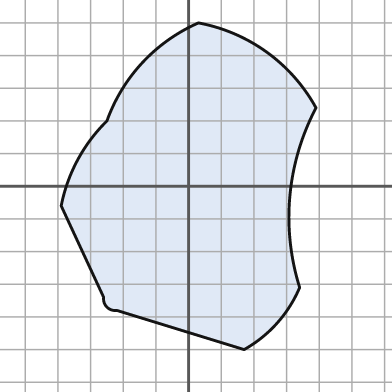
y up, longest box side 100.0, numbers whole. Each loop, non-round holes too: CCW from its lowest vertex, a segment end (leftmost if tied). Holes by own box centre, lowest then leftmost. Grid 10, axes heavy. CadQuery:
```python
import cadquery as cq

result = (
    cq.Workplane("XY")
    .moveTo(17.0, -50.0)
    .threePointArc((27.0, -42.0), (34.0, -31.0))
    .threePointArc((31.0, -3.0), (39.0, 24.0))
    .threePointArc((24.0, 41.0), (3.0, 50.0))
    .threePointArc((-14.0, 38.0), (-25.0, 20.0))
    .threePointArc((-34.0, 8.0), (-39.0, -6.0))
    .lineTo(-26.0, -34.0)
    .threePointArc((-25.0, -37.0), (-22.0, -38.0))
    .close()
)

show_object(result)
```